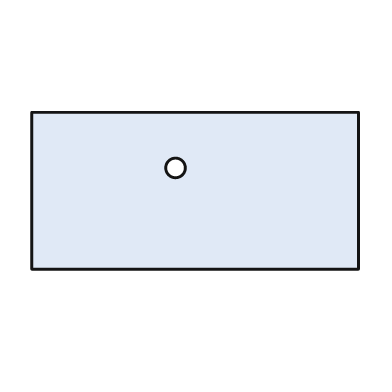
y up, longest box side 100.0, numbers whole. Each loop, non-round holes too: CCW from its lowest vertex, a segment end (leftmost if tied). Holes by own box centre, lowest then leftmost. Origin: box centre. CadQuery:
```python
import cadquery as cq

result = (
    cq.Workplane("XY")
    .moveTo(-50.0, -24.0)
    .lineTo(50.0, -24.0)
    .lineTo(50.0, 24.0)
    .lineTo(-50.0, 24.0)
    .close()
    .moveTo(-6.0, 7.0)
    .circle(3.0)
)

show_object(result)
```